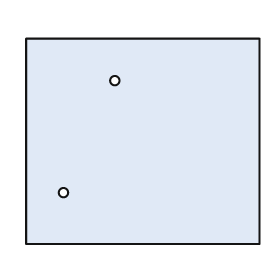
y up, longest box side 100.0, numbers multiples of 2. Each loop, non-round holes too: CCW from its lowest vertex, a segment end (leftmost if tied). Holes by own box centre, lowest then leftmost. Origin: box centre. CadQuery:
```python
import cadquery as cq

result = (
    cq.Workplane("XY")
    .moveTo(-50.0, -44.0)
    .lineTo(50.0, -44.0)
    .lineTo(50.0, 44.0)
    .lineTo(-50.0, 44.0)
    .close()
    .moveTo(-34.0, -22.0)
    .circle(2.0)
    .moveTo(-12.0, 26.0)
    .circle(2.0)
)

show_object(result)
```